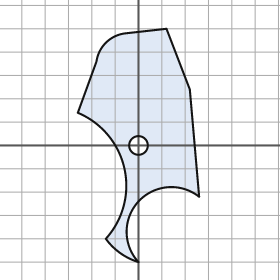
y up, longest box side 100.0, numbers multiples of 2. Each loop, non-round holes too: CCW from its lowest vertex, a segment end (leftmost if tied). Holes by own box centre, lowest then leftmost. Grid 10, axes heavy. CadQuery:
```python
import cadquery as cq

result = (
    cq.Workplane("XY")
    .moveTo(0.0, -50.0)
    .threePointArc((0.0, -24.0), (26.0, -22.0))
    .lineTo(22.0, 24.0)
    .lineTo(12.0, 50.0)
    .lineTo(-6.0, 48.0)
    .threePointArc((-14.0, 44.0), (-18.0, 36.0))
    .lineTo(-26.0, 14.0)
    .threePointArc((-6.0, -10.0), (-14.0, -40.0))
    .threePointArc((-8.0, -46.0), (0.0, -50.0))
    .close()
    .moveTo(0.0, 0.0)
    .circle(4.0)
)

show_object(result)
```